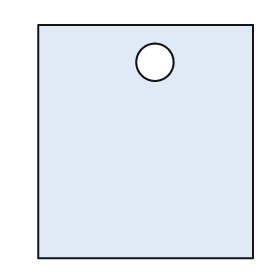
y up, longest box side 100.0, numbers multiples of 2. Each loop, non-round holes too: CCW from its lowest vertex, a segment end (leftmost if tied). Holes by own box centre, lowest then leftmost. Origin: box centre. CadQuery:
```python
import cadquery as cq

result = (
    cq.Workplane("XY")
    .moveTo(-46.0, -50.0)
    .lineTo(46.0, -50.0)
    .lineTo(46.0, 50.0)
    .lineTo(-46.0, 50.0)
    .close()
    .moveTo(4.0, 34.0)
    .circle(8.0)
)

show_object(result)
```